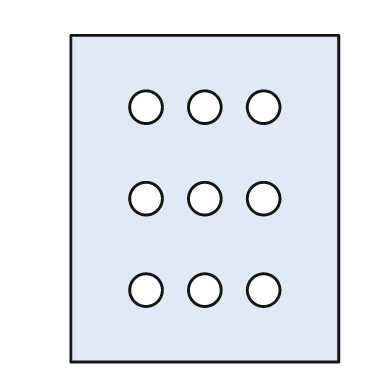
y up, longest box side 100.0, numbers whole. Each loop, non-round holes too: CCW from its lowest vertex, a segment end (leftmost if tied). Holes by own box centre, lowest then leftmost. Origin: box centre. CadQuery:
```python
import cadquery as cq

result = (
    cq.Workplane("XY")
    .moveTo(-41.0, -50.0)
    .lineTo(41.0, -50.0)
    .lineTo(41.0, 50.0)
    .lineTo(-41.0, 50.0)
    .close()
    .moveTo(-18.0, -28.0)
    .circle(5.0)
    .moveTo(0.0, -28.0)
    .circle(5.0)
    .moveTo(18.0, -28.0)
    .circle(5.0)
    .moveTo(-18.0, 0.0)
    .circle(5.0)
    .moveTo(0.0, 0.0)
    .circle(5.0)
    .moveTo(18.0, 0.0)
    .circle(5.0)
    .moveTo(-18.0, 28.0)
    .circle(5.0)
    .moveTo(0.0, 28.0)
    .circle(5.0)
    .moveTo(18.0, 28.0)
    .circle(5.0)
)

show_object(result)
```